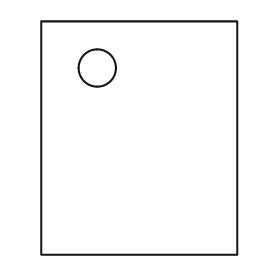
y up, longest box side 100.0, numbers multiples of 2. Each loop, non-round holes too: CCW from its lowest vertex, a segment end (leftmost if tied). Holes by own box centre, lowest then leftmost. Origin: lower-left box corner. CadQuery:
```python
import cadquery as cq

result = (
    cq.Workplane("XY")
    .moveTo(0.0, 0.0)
    .lineTo(84.0, 0.0)
    .lineTo(84.0, 100.0)
    .lineTo(0.0, 100.0)
    .close()
    .moveTo(24.0, 80.0)
    .circle(8.0)
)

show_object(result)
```